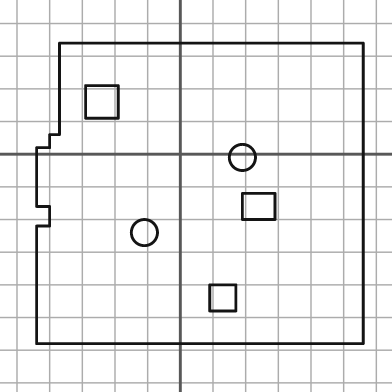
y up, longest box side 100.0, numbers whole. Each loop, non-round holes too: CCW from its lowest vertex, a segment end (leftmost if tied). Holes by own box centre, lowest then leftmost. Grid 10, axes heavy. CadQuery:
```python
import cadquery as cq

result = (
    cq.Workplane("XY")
    .moveTo(-44.0, -58.0)
    .lineTo(56.0, -58.0)
    .lineTo(56.0, 34.0)
    .lineTo(-37.0, 34.0)
    .lineTo(-37.0, 6.0)
    .lineTo(-40.0, 6.0)
    .lineTo(-40.0, 2.0)
    .lineTo(-44.0, 2.0)
    .lineTo(-44.0, -16.0)
    .lineTo(-40.0, -16.0)
    .lineTo(-40.0, -22.0)
    .lineTo(-44.0, -22.0)
    .close()
    .moveTo(9.0, -48.0)
    .lineTo(17.0, -48.0)
    .lineTo(17.0, -40.0)
    .lineTo(9.0, -40.0)
    .close()
    .moveTo(-11.0, -24.0)
    .circle(4.0)
    .moveTo(19.0, -20.0)
    .lineTo(29.0, -20.0)
    .lineTo(29.0, -12.0)
    .lineTo(19.0, -12.0)
    .close()
    .moveTo(19.0, -1.0)
    .circle(4.0)
    .moveTo(-29.0, 11.0)
    .lineTo(-19.0, 11.0)
    .lineTo(-19.0, 21.0)
    .lineTo(-29.0, 21.0)
    .close()
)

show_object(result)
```